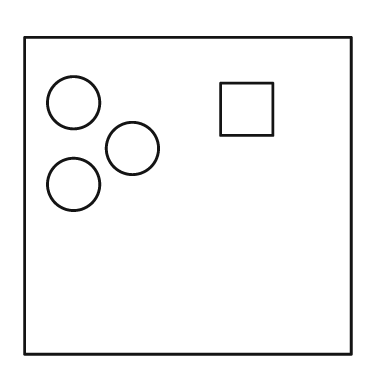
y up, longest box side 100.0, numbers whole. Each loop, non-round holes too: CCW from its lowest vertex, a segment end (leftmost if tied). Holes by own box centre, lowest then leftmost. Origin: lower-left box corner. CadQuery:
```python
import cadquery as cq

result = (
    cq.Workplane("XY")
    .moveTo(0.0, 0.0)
    .lineTo(100.0, 0.0)
    .lineTo(100.0, 97.0)
    .lineTo(0.0, 97.0)
    .close()
    .moveTo(15.0, 52.0)
    .circle(8.0)
    .moveTo(33.0, 63.0)
    .circle(8.0)
    .moveTo(60.0, 67.0)
    .lineTo(76.0, 67.0)
    .lineTo(76.0, 83.0)
    .lineTo(60.0, 83.0)
    .close()
    .moveTo(15.0, 77.0)
    .circle(8.0)
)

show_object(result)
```